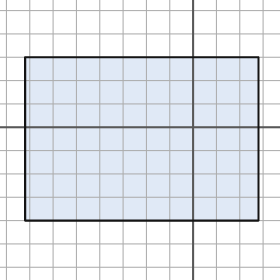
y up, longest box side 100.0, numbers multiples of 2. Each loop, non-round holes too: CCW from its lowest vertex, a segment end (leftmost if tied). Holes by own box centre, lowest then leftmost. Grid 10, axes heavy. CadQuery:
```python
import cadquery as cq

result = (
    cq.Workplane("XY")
    .moveTo(-72.0, -40.0)
    .lineTo(28.0, -40.0)
    .lineTo(28.0, 30.0)
    .lineTo(-72.0, 30.0)
    .close()
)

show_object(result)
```